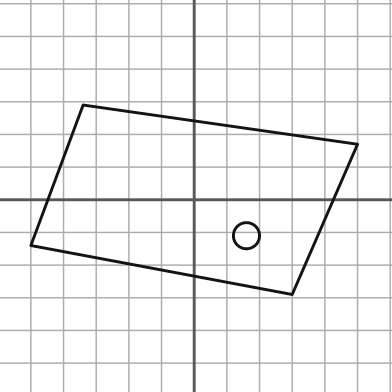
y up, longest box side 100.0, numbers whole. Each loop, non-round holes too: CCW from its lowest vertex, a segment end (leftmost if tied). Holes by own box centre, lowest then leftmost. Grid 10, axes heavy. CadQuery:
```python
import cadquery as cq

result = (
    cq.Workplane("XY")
    .moveTo(30.0, -29.0)
    .lineTo(50.0, 17.0)
    .lineTo(-34.0, 29.0)
    .lineTo(-50.0, -14.0)
    .close()
    .moveTo(16.0, -11.0)
    .circle(4.0)
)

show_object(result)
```